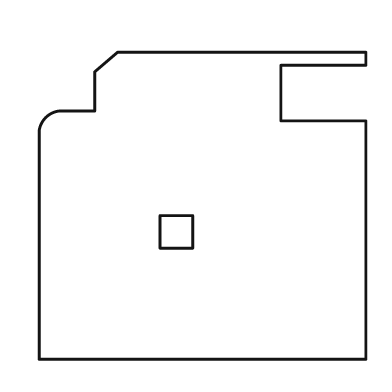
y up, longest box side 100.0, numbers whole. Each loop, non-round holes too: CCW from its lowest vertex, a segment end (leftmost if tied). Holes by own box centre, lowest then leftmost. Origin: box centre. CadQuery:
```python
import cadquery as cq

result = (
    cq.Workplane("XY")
    .moveTo(-50.0, -47.0)
    .lineTo(50.0, -47.0)
    .lineTo(50.0, 26.0)
    .lineTo(24.0, 26.0)
    .lineTo(24.0, 43.0)
    .lineTo(50.0, 43.0)
    .lineTo(50.0, 47.0)
    .lineTo(-26.0, 47.0)
    .lineTo(-33.0, 41.0)
    .lineTo(-33.0, 29.0)
    .lineTo(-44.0, 29.0)
    .threePointArc((-48.0, 27.0), (-50.0, 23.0))
    .close()
    .moveTo(-13.0, -13.0)
    .lineTo(-3.0, -13.0)
    .lineTo(-3.0, -3.0)
    .lineTo(-13.0, -3.0)
    .close()
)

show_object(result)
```